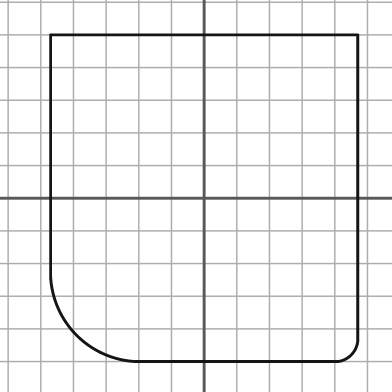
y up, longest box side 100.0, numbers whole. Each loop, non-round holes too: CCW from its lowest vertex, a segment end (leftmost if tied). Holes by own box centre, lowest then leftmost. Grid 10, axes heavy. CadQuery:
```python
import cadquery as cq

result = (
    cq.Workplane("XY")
    .moveTo(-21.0, -50.0)
    .lineTo(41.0, -50.0)
    .threePointArc((45.0, -48.0), (47.0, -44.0))
    .lineTo(47.0, 50.0)
    .lineTo(-47.0, 50.0)
    .lineTo(-47.0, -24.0)
    .threePointArc((-39.0, -42.0), (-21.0, -50.0))
    .close()
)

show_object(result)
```